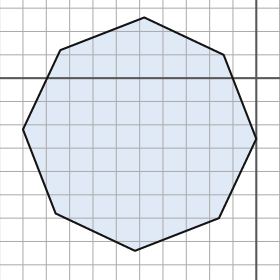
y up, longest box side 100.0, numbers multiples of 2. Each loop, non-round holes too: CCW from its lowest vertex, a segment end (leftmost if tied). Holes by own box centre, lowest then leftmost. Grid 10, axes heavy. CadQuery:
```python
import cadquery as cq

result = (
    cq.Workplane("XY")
    .moveTo(-52.0, -74.0)
    .lineTo(-16.0, -60.0)
    .lineTo(0.0, -26.0)
    .lineTo(-14.0, 10.0)
    .lineTo(-48.0, 26.0)
    .lineTo(-84.0, 12.0)
    .lineTo(-100.0, -22.0)
    .lineTo(-86.0, -58.0)
    .close()
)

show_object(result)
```